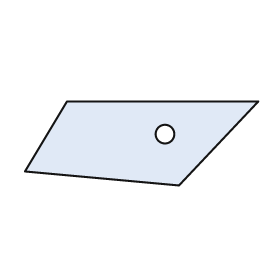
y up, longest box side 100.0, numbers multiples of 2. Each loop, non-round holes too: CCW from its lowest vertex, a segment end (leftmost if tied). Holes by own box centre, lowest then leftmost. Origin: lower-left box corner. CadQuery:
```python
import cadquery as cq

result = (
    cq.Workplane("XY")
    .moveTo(66.0, 0.0)
    .lineTo(100.0, 36.0)
    .lineTo(18.0, 36.0)
    .lineTo(0.0, 6.0)
    .close()
    .moveTo(60.0, 22.0)
    .circle(4.0)
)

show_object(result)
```